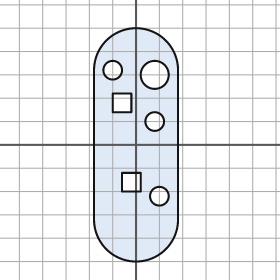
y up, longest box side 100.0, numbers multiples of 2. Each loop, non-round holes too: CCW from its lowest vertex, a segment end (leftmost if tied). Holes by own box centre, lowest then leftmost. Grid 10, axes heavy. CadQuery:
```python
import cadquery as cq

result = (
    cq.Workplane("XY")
    .moveTo(-18.0, -32.0)
    .threePointArc((0.0, -50.0), (18.0, -32.0))
    .lineTo(18.0, 32.0)
    .threePointArc((0.0, 50.0), (-18.0, 32.0))
    .close()
    .moveTo(10.0, -22.0)
    .circle(4.0)
    .moveTo(-6.0, -20.0)
    .lineTo(2.0, -20.0)
    .lineTo(2.0, -12.0)
    .lineTo(-6.0, -12.0)
    .close()
    .moveTo(8.0, 10.0)
    .circle(4.0)
    .moveTo(-10.0, 14.0)
    .lineTo(-2.0, 14.0)
    .lineTo(-2.0, 22.0)
    .lineTo(-10.0, 22.0)
    .close()
    .moveTo(8.0, 30.0)
    .circle(6.0)
    .moveTo(-10.0, 32.0)
    .circle(4.0)
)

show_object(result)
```